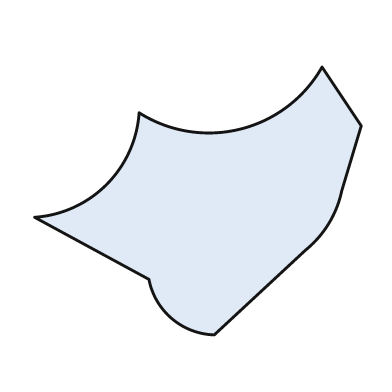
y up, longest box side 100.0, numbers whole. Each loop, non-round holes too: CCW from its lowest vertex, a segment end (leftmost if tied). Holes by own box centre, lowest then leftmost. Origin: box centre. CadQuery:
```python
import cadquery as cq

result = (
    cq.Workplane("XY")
    .moveTo(5.0, -41.0)
    .lineTo(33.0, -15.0)
    .threePointArc((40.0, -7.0), (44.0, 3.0))
    .lineTo(50.0, 23.0)
    .lineTo(38.0, 41.0)
    .threePointArc((13.0, 22.0), (-18.0, 27.0))
    .threePointArc((-28.0, 5.0), (-50.0, -5.0))
    .lineTo(-15.0, -24.0)
    .threePointArc((-8.0, -36.0), (5.0, -41.0))
    .close()
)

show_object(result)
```